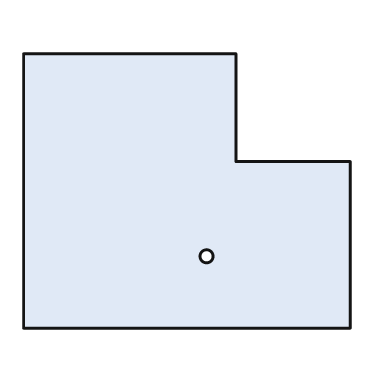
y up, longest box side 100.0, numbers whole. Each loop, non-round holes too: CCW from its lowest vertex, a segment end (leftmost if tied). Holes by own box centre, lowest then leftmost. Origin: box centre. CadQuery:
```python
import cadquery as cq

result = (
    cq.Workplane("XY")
    .moveTo(-50.0, -42.0)
    .lineTo(50.0, -42.0)
    .lineTo(50.0, 9.0)
    .lineTo(15.0, 9.0)
    .lineTo(15.0, 42.0)
    .lineTo(-50.0, 42.0)
    .close()
    .moveTo(6.0, -20.0)
    .circle(2.0)
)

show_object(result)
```